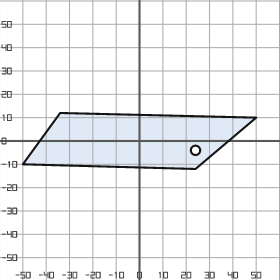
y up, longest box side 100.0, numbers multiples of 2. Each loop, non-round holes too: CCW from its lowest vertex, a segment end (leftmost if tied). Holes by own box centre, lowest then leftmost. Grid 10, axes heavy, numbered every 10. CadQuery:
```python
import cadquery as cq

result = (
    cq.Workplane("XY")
    .moveTo(24.0, -12.0)
    .lineTo(50.0, 10.0)
    .lineTo(-34.0, 12.0)
    .lineTo(-50.0, -10.0)
    .close()
    .moveTo(24.0, -4.0)
    .circle(2.0)
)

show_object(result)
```